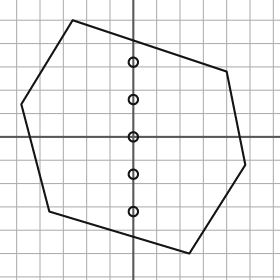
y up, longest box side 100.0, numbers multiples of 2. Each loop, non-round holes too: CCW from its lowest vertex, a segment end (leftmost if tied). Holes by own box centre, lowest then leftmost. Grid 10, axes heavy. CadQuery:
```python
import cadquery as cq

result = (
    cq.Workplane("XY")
    .moveTo(24.0, -50.0)
    .lineTo(48.0, -12.0)
    .lineTo(40.0, 28.0)
    .lineTo(-26.0, 50.0)
    .lineTo(-48.0, 14.0)
    .lineTo(-36.0, -32.0)
    .close()
    .moveTo(0.0, -32.0)
    .circle(2.0)
    .moveTo(0.0, -16.0)
    .circle(2.0)
    .moveTo(0.0, 0.0)
    .circle(2.0)
    .moveTo(0.0, 16.0)
    .circle(2.0)
    .moveTo(0.0, 32.0)
    .circle(2.0)
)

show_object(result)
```